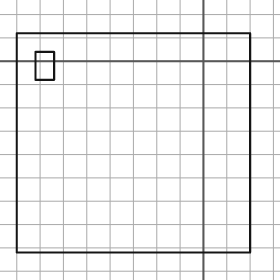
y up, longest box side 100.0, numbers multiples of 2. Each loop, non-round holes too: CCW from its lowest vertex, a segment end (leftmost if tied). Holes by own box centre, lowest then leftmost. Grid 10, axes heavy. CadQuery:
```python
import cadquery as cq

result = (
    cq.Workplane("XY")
    .moveTo(-80.0, -82.0)
    .lineTo(20.0, -82.0)
    .lineTo(20.0, 12.0)
    .lineTo(-80.0, 12.0)
    .close()
    .moveTo(-72.0, -8.0)
    .lineTo(-64.0, -8.0)
    .lineTo(-64.0, 4.0)
    .lineTo(-72.0, 4.0)
    .close()
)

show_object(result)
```